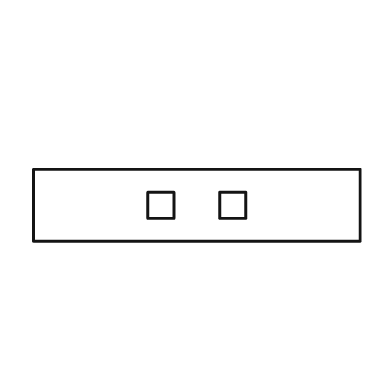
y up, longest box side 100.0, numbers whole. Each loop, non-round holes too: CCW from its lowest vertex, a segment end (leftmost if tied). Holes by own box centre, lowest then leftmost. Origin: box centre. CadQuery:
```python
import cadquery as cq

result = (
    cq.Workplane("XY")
    .moveTo(-50.0, -11.0)
    .lineTo(50.0, -11.0)
    .lineTo(50.0, 11.0)
    .lineTo(-50.0, 11.0)
    .close()
    .moveTo(-15.0, -4.0)
    .lineTo(-7.0, -4.0)
    .lineTo(-7.0, 4.0)
    .lineTo(-15.0, 4.0)
    .close()
    .moveTo(7.0, -4.0)
    .lineTo(15.0, -4.0)
    .lineTo(15.0, 4.0)
    .lineTo(7.0, 4.0)
    .close()
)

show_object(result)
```